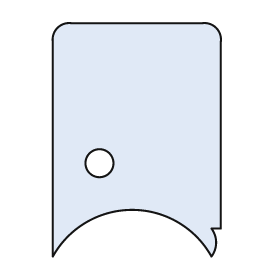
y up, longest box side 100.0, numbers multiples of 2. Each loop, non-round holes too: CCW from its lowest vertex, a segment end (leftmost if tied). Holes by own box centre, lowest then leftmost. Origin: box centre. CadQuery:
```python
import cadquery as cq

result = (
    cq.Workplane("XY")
    .moveTo(-36.0, -50.0)
    .threePointArc((-2.0, -30.0), (32.0, -50.0))
    .threePointArc((34.0, -44.0), (32.0, -38.0))
    .lineTo(36.0, -38.0)
    .lineTo(36.0, 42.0)
    .threePointArc((34.0, 48.0), (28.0, 50.0))
    .lineTo(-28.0, 50.0)
    .threePointArc((-34.0, 48.0), (-36.0, 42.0))
    .close()
    .moveTo(-16.0, -10.0)
    .circle(6.0)
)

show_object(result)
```